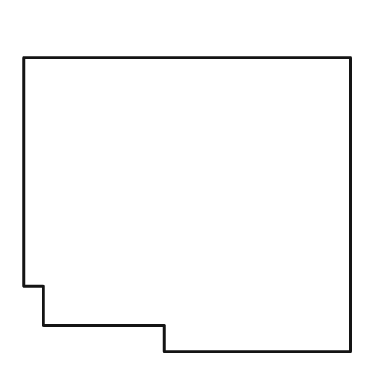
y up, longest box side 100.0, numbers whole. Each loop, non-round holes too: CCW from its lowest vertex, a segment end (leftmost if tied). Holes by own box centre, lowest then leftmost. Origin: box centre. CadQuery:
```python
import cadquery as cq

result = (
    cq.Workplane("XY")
    .moveTo(-7.0, -45.0)
    .lineTo(50.0, -45.0)
    .lineTo(50.0, 45.0)
    .lineTo(-50.0, 45.0)
    .lineTo(-50.0, -25.0)
    .lineTo(-44.0, -25.0)
    .lineTo(-44.0, -37.0)
    .lineTo(-7.0, -37.0)
    .close()
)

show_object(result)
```